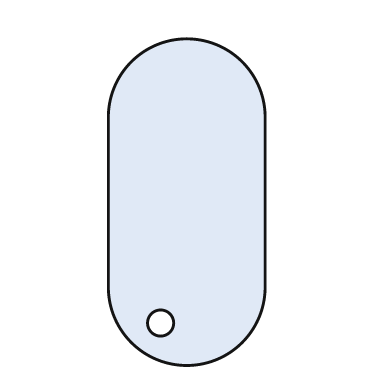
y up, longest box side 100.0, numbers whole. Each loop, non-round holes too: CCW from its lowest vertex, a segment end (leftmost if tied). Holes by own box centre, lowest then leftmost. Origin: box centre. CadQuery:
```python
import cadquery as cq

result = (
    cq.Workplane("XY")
    .moveTo(-24.0, -26.0)
    .threePointArc((0.0, -50.0), (24.0, -26.0))
    .lineTo(24.0, 26.0)
    .threePointArc((0.0, 50.0), (-24.0, 26.0))
    .close()
    .moveTo(-8.0, -37.0)
    .circle(4.0)
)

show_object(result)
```